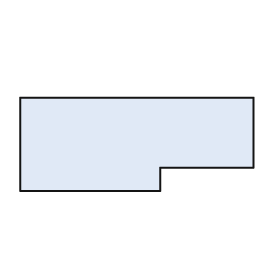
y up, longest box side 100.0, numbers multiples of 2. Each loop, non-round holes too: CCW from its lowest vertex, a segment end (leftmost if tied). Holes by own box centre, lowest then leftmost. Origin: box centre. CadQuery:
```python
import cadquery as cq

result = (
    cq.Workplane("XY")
    .moveTo(-50.0, -20.0)
    .lineTo(10.0, -20.0)
    .lineTo(10.0, -10.0)
    .lineTo(50.0, -10.0)
    .lineTo(50.0, 20.0)
    .lineTo(-50.0, 20.0)
    .close()
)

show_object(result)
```